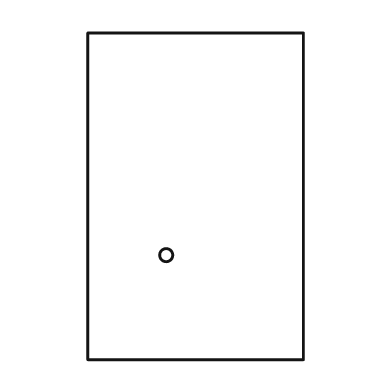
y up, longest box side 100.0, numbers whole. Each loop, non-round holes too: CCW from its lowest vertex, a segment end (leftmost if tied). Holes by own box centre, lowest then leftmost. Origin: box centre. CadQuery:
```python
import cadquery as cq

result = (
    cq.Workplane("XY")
    .moveTo(-33.0, -50.0)
    .lineTo(33.0, -50.0)
    .lineTo(33.0, 50.0)
    .lineTo(-33.0, 50.0)
    .close()
    .moveTo(-9.0, -18.0)
    .circle(2.0)
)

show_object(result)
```